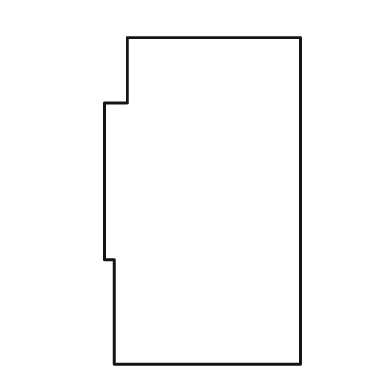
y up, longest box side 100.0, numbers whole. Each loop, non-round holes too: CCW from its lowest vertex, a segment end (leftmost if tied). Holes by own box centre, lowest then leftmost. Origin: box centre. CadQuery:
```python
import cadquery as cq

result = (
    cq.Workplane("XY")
    .moveTo(-27.0, -50.0)
    .lineTo(30.0, -50.0)
    .lineTo(30.0, 50.0)
    .lineTo(-23.0, 50.0)
    .lineTo(-23.0, 30.0)
    .lineTo(-30.0, 30.0)
    .lineTo(-30.0, -18.0)
    .lineTo(-27.0, -18.0)
    .close()
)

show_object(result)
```